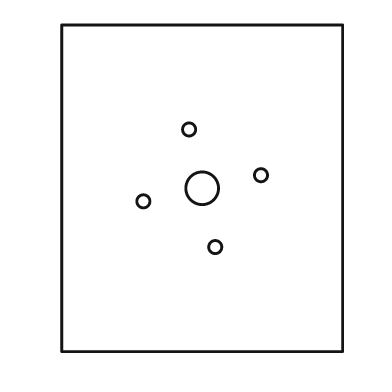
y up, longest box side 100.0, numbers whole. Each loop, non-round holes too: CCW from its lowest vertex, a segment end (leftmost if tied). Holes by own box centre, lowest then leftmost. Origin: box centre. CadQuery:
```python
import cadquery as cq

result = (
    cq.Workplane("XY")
    .moveTo(-43.0, -50.0)
    .lineTo(43.0, -50.0)
    .lineTo(43.0, 50.0)
    .lineTo(-43.0, 50.0)
    .close()
    .moveTo(4.0, -18.0)
    .circle(2.0)
    .moveTo(-18.0, -4.0)
    .circle(2.0)
    .moveTo(0.0, 0.0)
    .circle(5.0)
    .moveTo(18.0, 4.0)
    .circle(2.0)
    .moveTo(-4.0, 18.0)
    .circle(2.0)
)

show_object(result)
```